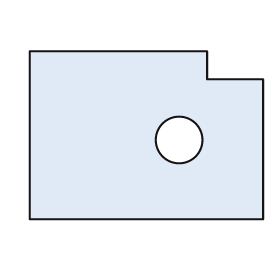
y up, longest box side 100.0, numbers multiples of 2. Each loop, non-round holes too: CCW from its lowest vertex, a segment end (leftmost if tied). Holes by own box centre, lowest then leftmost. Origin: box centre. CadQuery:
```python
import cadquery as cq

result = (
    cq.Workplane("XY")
    .moveTo(-50.0, -36.0)
    .lineTo(50.0, -36.0)
    .lineTo(50.0, 24.0)
    .lineTo(26.0, 24.0)
    .lineTo(26.0, 36.0)
    .lineTo(-50.0, 36.0)
    .close()
    .moveTo(14.0, -2.0)
    .circle(10.0)
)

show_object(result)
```